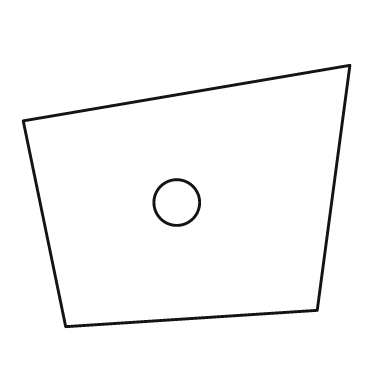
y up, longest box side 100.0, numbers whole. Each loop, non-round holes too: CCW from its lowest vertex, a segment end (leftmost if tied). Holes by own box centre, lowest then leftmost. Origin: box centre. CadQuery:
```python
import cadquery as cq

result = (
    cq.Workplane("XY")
    .moveTo(-37.0, -40.0)
    .lineTo(40.0, -35.0)
    .lineTo(50.0, 40.0)
    .lineTo(-50.0, 23.0)
    .close()
    .moveTo(-3.0, -2.0)
    .circle(7.0)
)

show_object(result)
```